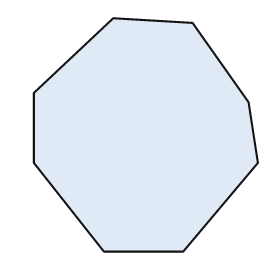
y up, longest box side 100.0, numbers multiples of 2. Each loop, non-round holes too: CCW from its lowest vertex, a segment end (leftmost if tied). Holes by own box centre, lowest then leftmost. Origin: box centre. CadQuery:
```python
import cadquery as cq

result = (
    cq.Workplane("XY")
    .moveTo(-18.0, -50.0)
    .lineTo(16.0, -50.0)
    .lineTo(48.0, -12.0)
    .lineTo(44.0, 14.0)
    .lineTo(20.0, 48.0)
    .lineTo(-14.0, 50.0)
    .lineTo(-48.0, 18.0)
    .lineTo(-48.0, -12.0)
    .close()
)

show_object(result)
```